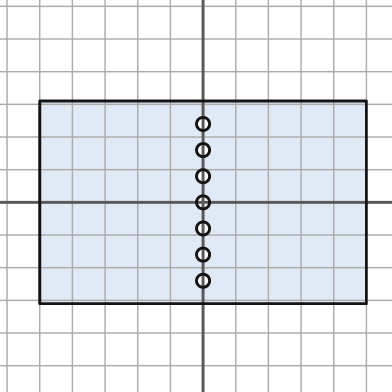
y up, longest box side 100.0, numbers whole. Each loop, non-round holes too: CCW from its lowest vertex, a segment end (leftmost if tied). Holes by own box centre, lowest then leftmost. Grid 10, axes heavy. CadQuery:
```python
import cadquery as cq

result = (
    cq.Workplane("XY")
    .moveTo(-50.0, -31.0)
    .lineTo(50.0, -31.0)
    .lineTo(50.0, 31.0)
    .lineTo(-50.0, 31.0)
    .close()
    .moveTo(0.0, -24.0)
    .circle(2.0)
    .moveTo(0.0, -16.0)
    .circle(2.0)
    .moveTo(0.0, -8.0)
    .circle(2.0)
    .moveTo(0.0, 0.0)
    .circle(2.0)
    .moveTo(0.0, 8.0)
    .circle(2.0)
    .moveTo(0.0, 16.0)
    .circle(2.0)
    .moveTo(0.0, 24.0)
    .circle(2.0)
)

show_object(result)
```